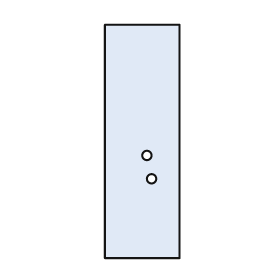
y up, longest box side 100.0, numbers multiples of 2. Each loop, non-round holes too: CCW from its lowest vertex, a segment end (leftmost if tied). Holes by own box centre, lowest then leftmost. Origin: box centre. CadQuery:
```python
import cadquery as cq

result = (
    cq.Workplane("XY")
    .moveTo(-16.0, -50.0)
    .lineTo(16.0, -50.0)
    .lineTo(16.0, 50.0)
    .lineTo(-16.0, 50.0)
    .close()
    .moveTo(4.0, -16.0)
    .circle(2.0)
    .moveTo(2.0, -6.0)
    .circle(2.0)
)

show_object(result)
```